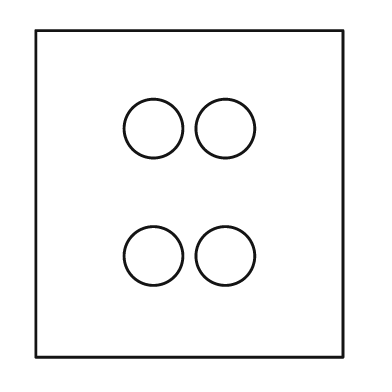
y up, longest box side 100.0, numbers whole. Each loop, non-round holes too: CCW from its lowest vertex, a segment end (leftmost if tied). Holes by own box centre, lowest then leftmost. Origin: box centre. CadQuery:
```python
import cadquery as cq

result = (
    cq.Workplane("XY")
    .moveTo(-47.0, -50.0)
    .lineTo(47.0, -50.0)
    .lineTo(47.0, 50.0)
    .lineTo(-47.0, 50.0)
    .close()
    .moveTo(-11.0, -19.0)
    .circle(9.0)
    .moveTo(11.0, -19.0)
    .circle(9.0)
    .moveTo(-11.0, 20.0)
    .circle(9.0)
    .moveTo(11.0, 20.0)
    .circle(9.0)
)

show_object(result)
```